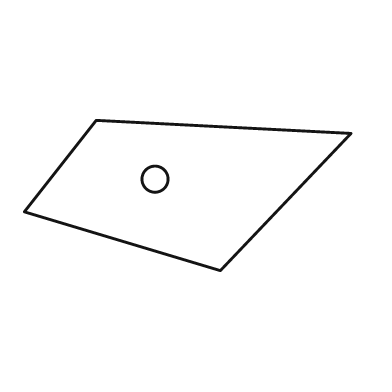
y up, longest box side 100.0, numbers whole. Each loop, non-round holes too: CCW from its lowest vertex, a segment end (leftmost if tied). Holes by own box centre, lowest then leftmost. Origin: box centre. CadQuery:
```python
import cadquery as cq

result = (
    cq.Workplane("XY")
    .moveTo(10.0, -23.0)
    .lineTo(50.0, 19.0)
    .lineTo(-28.0, 23.0)
    .lineTo(-50.0, -5.0)
    .close()
    .moveTo(-10.0, 5.0)
    .circle(4.0)
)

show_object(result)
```